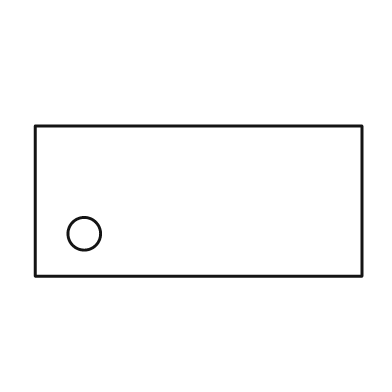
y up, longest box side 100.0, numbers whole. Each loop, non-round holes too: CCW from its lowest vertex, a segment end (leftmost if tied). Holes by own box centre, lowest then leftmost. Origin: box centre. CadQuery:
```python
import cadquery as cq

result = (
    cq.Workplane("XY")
    .moveTo(-50.0, -23.0)
    .lineTo(50.0, -23.0)
    .lineTo(50.0, 23.0)
    .lineTo(-50.0, 23.0)
    .close()
    .moveTo(-35.0, -10.0)
    .circle(5.0)
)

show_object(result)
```